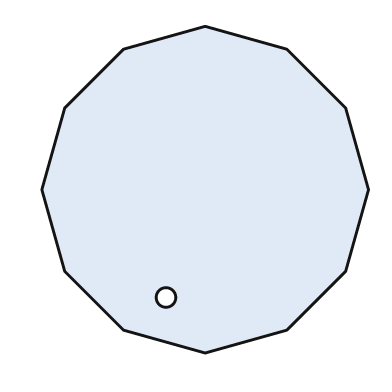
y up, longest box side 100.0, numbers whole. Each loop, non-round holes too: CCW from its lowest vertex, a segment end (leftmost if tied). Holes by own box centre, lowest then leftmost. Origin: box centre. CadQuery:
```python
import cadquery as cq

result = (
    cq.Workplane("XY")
    .moveTo(0.0, -50.0)
    .lineTo(25.0, -43.0)
    .lineTo(43.0, -25.0)
    .lineTo(50.0, 0.0)
    .lineTo(43.0, 25.0)
    .lineTo(25.0, 43.0)
    .lineTo(0.0, 50.0)
    .lineTo(-25.0, 43.0)
    .lineTo(-43.0, 25.0)
    .lineTo(-50.0, 0.0)
    .lineTo(-43.0, -25.0)
    .lineTo(-25.0, -43.0)
    .close()
    .moveTo(-12.0, -33.0)
    .circle(3.0)
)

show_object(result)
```